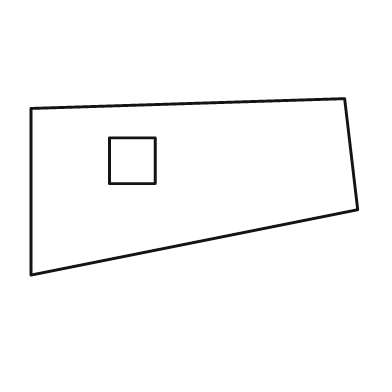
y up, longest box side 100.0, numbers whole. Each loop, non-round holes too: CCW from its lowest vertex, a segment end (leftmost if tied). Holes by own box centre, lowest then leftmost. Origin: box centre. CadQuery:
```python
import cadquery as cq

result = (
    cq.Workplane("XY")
    .moveTo(-50.0, -27.0)
    .lineTo(50.0, -7.0)
    .lineTo(46.0, 27.0)
    .lineTo(-50.0, 24.0)
    .close()
    .moveTo(-26.0, 1.0)
    .lineTo(-12.0, 1.0)
    .lineTo(-12.0, 15.0)
    .lineTo(-26.0, 15.0)
    .close()
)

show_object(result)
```